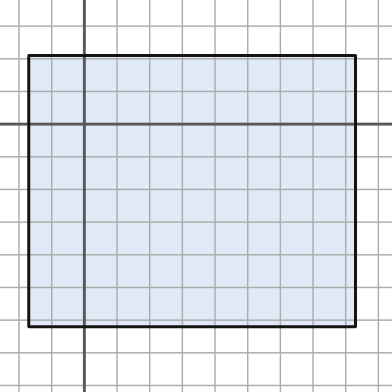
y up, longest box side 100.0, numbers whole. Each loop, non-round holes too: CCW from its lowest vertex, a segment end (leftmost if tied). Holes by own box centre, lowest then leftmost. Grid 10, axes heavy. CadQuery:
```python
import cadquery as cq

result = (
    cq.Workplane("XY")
    .moveTo(-17.0, -62.0)
    .lineTo(83.0, -62.0)
    .lineTo(83.0, 21.0)
    .lineTo(-17.0, 21.0)
    .close()
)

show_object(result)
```